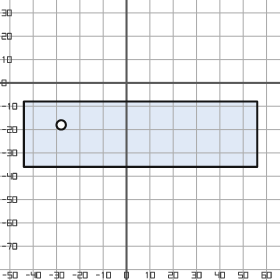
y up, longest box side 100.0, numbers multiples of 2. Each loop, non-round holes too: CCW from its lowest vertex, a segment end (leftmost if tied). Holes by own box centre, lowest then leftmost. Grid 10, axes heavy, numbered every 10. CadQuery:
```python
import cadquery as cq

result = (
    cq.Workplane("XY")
    .moveTo(-44.0, -36.0)
    .lineTo(56.0, -36.0)
    .lineTo(56.0, -8.0)
    .lineTo(-44.0, -8.0)
    .close()
    .moveTo(-28.0, -18.0)
    .circle(2.0)
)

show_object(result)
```